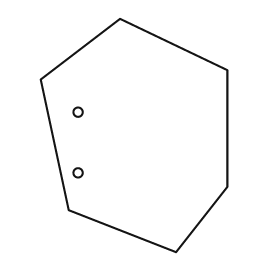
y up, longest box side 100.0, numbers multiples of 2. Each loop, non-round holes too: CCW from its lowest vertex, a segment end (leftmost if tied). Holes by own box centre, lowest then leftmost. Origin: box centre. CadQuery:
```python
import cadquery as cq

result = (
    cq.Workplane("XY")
    .moveTo(18.0, -50.0)
    .lineTo(40.0, -22.0)
    .lineTo(40.0, 28.0)
    .lineTo(-6.0, 50.0)
    .lineTo(-40.0, 24.0)
    .lineTo(-28.0, -32.0)
    .close()
    .moveTo(-24.0, -16.0)
    .circle(2.0)
    .moveTo(-24.0, 10.0)
    .circle(2.0)
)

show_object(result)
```